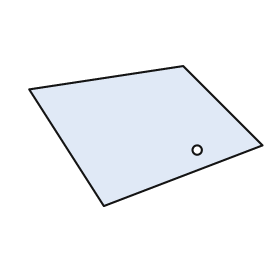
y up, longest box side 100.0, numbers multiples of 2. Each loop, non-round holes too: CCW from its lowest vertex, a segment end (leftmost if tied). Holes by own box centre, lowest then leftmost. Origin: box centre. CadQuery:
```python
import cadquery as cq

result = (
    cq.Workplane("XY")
    .moveTo(-18.0, -30.0)
    .lineTo(50.0, -4.0)
    .lineTo(16.0, 30.0)
    .lineTo(-50.0, 20.0)
    .close()
    .moveTo(22.0, -6.0)
    .circle(2.0)
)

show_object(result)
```